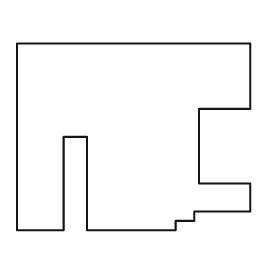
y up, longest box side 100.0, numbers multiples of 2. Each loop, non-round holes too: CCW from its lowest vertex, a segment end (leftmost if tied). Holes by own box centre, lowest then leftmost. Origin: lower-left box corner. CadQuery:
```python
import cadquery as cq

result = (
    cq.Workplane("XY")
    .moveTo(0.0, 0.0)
    .lineTo(20.0, 0.0)
    .lineTo(20.0, 40.0)
    .lineTo(30.0, 40.0)
    .lineTo(30.0, 0.0)
    .lineTo(68.0, 0.0)
    .lineTo(68.0, 4.0)
    .lineTo(76.0, 4.0)
    .lineTo(76.0, 8.0)
    .lineTo(100.0, 8.0)
    .lineTo(100.0, 20.0)
    .lineTo(78.0, 20.0)
    .lineTo(78.0, 52.0)
    .lineTo(100.0, 52.0)
    .lineTo(100.0, 80.0)
    .lineTo(0.0, 80.0)
    .close()
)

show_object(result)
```